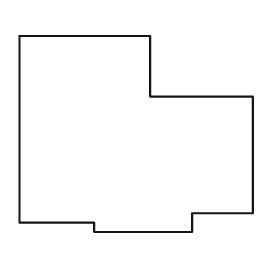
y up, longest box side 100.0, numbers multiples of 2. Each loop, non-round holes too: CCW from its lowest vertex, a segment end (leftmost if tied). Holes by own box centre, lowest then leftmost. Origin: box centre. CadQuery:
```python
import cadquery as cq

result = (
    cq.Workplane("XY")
    .moveTo(-18.0, -42.0)
    .lineTo(24.0, -42.0)
    .lineTo(24.0, -34.0)
    .lineTo(50.0, -34.0)
    .lineTo(50.0, 16.0)
    .lineTo(6.0, 16.0)
    .lineTo(6.0, 42.0)
    .lineTo(-50.0, 42.0)
    .lineTo(-50.0, -38.0)
    .lineTo(-18.0, -38.0)
    .close()
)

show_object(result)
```